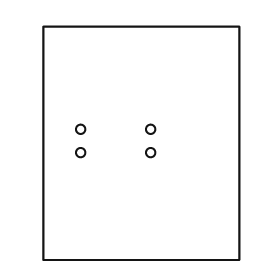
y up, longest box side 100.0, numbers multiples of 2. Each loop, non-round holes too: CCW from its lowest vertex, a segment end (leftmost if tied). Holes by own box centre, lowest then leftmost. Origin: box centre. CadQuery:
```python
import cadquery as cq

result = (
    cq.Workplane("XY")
    .moveTo(-42.0, -50.0)
    .lineTo(42.0, -50.0)
    .lineTo(42.0, 50.0)
    .lineTo(-42.0, 50.0)
    .close()
    .moveTo(-26.0, -4.0)
    .circle(2.0)
    .moveTo(4.0, -4.0)
    .circle(2.0)
    .moveTo(-26.0, 6.0)
    .circle(2.0)
    .moveTo(4.0, 6.0)
    .circle(2.0)
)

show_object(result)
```